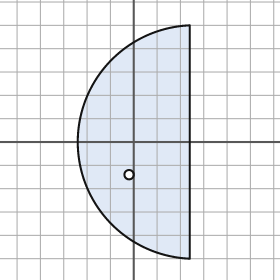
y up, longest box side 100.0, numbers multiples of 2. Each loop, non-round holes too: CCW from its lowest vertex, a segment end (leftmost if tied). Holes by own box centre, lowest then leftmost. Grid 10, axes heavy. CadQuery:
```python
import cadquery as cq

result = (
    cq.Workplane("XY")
    .moveTo(24.0, -50.0)
    .lineTo(24.0, 50.0)
    .threePointArc((-24.0, 0.0), (24.0, -50.0))
    .close()
    .moveTo(-2.0, -14.0)
    .circle(2.0)
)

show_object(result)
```